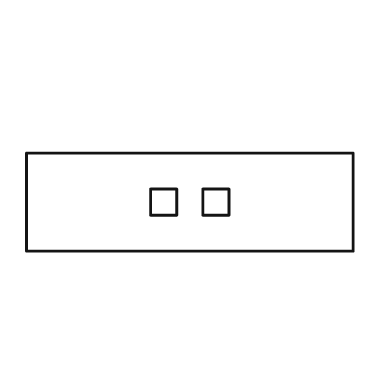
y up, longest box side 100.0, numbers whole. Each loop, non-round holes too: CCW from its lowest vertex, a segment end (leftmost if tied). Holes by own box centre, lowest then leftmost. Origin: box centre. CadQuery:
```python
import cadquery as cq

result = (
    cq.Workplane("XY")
    .moveTo(-50.0, -15.0)
    .lineTo(50.0, -15.0)
    .lineTo(50.0, 15.0)
    .lineTo(-50.0, 15.0)
    .close()
    .moveTo(-12.0, -4.0)
    .lineTo(-4.0, -4.0)
    .lineTo(-4.0, 4.0)
    .lineTo(-12.0, 4.0)
    .close()
    .moveTo(4.0, -4.0)
    .lineTo(12.0, -4.0)
    .lineTo(12.0, 4.0)
    .lineTo(4.0, 4.0)
    .close()
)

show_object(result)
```